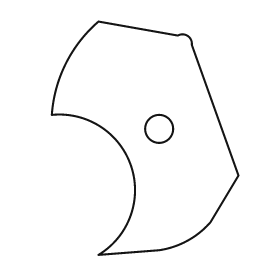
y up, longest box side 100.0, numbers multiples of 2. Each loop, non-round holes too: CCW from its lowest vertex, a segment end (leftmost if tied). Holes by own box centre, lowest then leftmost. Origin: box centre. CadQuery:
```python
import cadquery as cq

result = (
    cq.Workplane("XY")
    .moveTo(-20.0, -50.0)
    .lineTo(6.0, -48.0)
    .threePointArc((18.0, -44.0), (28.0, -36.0))
    .lineTo(40.0, -16.0)
    .lineTo(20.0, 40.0)
    .threePointArc((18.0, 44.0), (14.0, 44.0))
    .lineTo(-20.0, 50.0)
    .threePointArc((-34.0, 32.0), (-40.0, 10.0))
    .threePointArc((-6.0, -12.0), (-20.0, -50.0))
    .close()
    .moveTo(6.0, 4.0)
    .circle(6.0)
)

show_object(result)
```